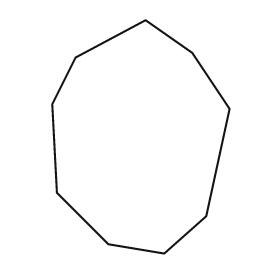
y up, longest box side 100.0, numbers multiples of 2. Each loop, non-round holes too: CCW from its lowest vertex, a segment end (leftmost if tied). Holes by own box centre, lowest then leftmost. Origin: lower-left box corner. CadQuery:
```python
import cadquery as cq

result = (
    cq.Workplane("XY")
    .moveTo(48.0, 0.0)
    .lineTo(66.0, 16.0)
    .lineTo(76.0, 62.0)
    .lineTo(60.0, 86.0)
    .lineTo(40.0, 100.0)
    .lineTo(10.0, 84.0)
    .lineTo(0.0, 64.0)
    .lineTo(2.0, 26.0)
    .lineTo(24.0, 4.0)
    .close()
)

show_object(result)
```